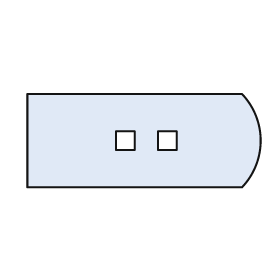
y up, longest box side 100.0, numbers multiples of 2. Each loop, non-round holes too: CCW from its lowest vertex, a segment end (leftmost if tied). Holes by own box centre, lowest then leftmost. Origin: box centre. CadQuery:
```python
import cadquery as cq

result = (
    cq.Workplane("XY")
    .moveTo(-50.0, -20.0)
    .lineTo(42.0, -20.0)
    .threePointArc((50.0, 0.0), (42.0, 20.0))
    .lineTo(-50.0, 20.0)
    .close()
    .moveTo(-12.0, -4.0)
    .lineTo(-4.0, -4.0)
    .lineTo(-4.0, 4.0)
    .lineTo(-12.0, 4.0)
    .close()
    .moveTo(6.0, -4.0)
    .lineTo(14.0, -4.0)
    .lineTo(14.0, 4.0)
    .lineTo(6.0, 4.0)
    .close()
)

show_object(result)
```